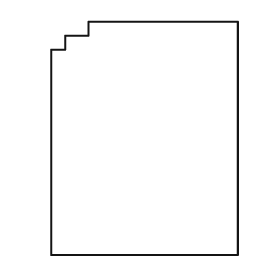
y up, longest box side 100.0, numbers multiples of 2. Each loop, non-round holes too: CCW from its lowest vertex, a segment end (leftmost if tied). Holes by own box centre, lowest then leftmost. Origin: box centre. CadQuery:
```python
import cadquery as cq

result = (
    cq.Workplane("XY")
    .moveTo(-40.0, -50.0)
    .lineTo(40.0, -50.0)
    .lineTo(40.0, 50.0)
    .lineTo(-24.0, 50.0)
    .lineTo(-24.0, 44.0)
    .lineTo(-34.0, 44.0)
    .lineTo(-34.0, 38.0)
    .lineTo(-40.0, 38.0)
    .close()
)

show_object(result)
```